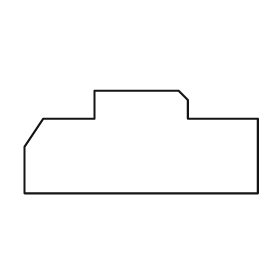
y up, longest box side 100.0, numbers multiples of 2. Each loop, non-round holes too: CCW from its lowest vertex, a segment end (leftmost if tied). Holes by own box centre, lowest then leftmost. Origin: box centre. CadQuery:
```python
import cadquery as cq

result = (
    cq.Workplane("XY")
    .moveTo(-50.0, -22.0)
    .lineTo(50.0, -22.0)
    .lineTo(50.0, 10.0)
    .lineTo(20.0, 10.0)
    .lineTo(20.0, 18.0)
    .lineTo(16.0, 22.0)
    .lineTo(-20.0, 22.0)
    .lineTo(-20.0, 10.0)
    .lineTo(-42.0, 10.0)
    .lineTo(-50.0, -2.0)
    .close()
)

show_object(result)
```